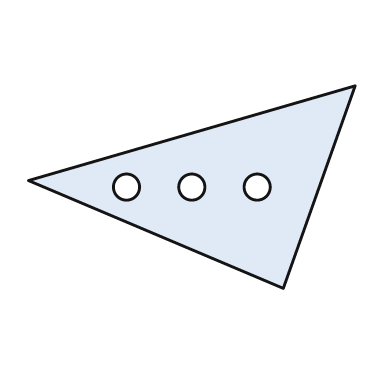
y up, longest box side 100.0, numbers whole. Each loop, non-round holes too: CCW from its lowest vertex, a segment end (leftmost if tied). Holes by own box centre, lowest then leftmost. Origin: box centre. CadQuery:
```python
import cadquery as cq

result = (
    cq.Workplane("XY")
    .moveTo(28.0, -31.0)
    .lineTo(50.0, 31.0)
    .lineTo(-50.0, 2.0)
    .close()
    .moveTo(-20.0, 0.0)
    .circle(4.0)
    .moveTo(0.0, 0.0)
    .circle(4.0)
    .moveTo(20.0, 0.0)
    .circle(4.0)
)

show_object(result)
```